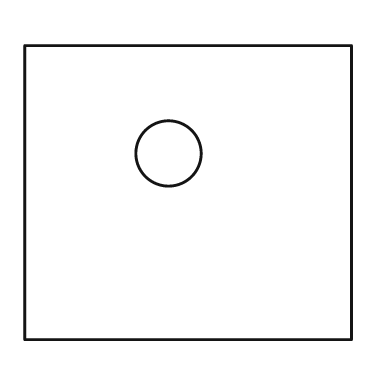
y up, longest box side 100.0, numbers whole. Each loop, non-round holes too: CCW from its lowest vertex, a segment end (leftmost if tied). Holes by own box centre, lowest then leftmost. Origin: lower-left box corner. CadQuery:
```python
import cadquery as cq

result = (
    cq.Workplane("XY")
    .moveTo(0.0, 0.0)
    .lineTo(100.0, 0.0)
    .lineTo(100.0, 90.0)
    .lineTo(0.0, 90.0)
    .close()
    .moveTo(44.0, 57.0)
    .circle(10.0)
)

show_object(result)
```